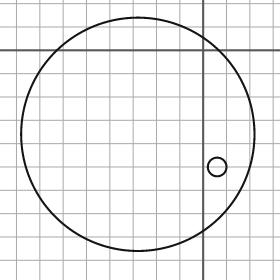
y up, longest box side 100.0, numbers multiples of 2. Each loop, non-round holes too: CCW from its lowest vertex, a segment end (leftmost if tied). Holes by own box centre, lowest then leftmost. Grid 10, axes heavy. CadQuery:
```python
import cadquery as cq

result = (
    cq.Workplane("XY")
    .moveTo(-28.0, -36.0)
    .circle(50.0)
    .moveTo(6.0, -50.0)
    .circle(4.0)
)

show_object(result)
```